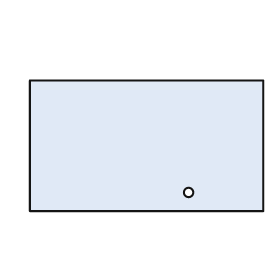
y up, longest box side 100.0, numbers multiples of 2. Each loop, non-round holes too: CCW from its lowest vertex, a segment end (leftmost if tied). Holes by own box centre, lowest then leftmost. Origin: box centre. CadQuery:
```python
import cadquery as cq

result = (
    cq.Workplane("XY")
    .moveTo(-50.0, -28.0)
    .lineTo(50.0, -28.0)
    .lineTo(50.0, 28.0)
    .lineTo(-50.0, 28.0)
    .close()
    .moveTo(18.0, -20.0)
    .circle(2.0)
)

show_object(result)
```